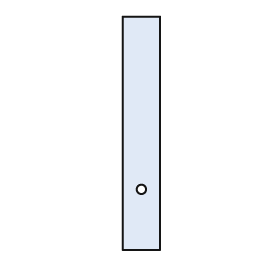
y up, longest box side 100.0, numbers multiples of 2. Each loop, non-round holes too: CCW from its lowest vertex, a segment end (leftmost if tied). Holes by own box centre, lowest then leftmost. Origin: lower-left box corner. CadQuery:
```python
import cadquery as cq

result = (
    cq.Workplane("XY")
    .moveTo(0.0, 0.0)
    .lineTo(16.0, 0.0)
    .lineTo(16.0, 100.0)
    .lineTo(0.0, 100.0)
    .close()
    .moveTo(8.0, 26.0)
    .circle(2.0)
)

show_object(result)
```